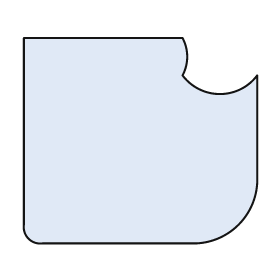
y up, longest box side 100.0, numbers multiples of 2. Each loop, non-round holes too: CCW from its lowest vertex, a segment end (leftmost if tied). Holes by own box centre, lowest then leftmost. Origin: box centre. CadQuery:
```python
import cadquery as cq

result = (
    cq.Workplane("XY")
    .moveTo(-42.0, -44.0)
    .lineTo(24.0, -44.0)
    .threePointArc((42.0, -36.0), (50.0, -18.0))
    .lineTo(50.0, 28.0)
    .threePointArc((34.0, 20.0), (18.0, 28.0))
    .threePointArc((20.0, 36.0), (18.0, 44.0))
    .lineTo(-50.0, 44.0)
    .lineTo(-50.0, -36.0)
    .threePointArc((-48.0, -42.0), (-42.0, -44.0))
    .close()
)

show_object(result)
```